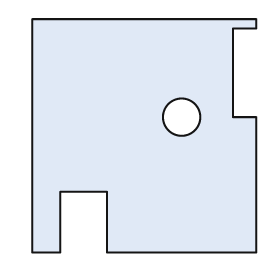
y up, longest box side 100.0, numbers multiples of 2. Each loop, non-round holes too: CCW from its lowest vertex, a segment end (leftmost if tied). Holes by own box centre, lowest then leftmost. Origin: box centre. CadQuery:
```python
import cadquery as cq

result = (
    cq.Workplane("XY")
    .moveTo(-48.0, -50.0)
    .lineTo(-36.0, -50.0)
    .lineTo(-36.0, -24.0)
    .lineTo(-16.0, -24.0)
    .lineTo(-16.0, -50.0)
    .lineTo(48.0, -50.0)
    .lineTo(48.0, 8.0)
    .lineTo(38.0, 8.0)
    .lineTo(38.0, 46.0)
    .lineTo(48.0, 46.0)
    .lineTo(48.0, 50.0)
    .lineTo(-48.0, 50.0)
    .close()
    .moveTo(16.0, 8.0)
    .circle(8.0)
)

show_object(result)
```